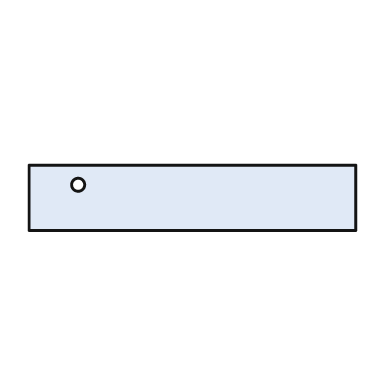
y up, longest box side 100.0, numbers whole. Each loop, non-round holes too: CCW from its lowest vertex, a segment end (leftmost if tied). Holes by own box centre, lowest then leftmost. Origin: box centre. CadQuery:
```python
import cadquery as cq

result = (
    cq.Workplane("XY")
    .moveTo(-50.0, -10.0)
    .lineTo(50.0, -10.0)
    .lineTo(50.0, 10.0)
    .lineTo(-50.0, 10.0)
    .close()
    .moveTo(-35.0, 4.0)
    .circle(2.0)
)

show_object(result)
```